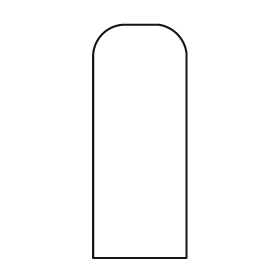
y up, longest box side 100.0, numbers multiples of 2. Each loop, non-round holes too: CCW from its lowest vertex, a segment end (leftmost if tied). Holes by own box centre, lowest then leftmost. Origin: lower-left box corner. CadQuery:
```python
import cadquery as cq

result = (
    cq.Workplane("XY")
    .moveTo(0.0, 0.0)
    .lineTo(40.0, 0.0)
    .lineTo(40.0, 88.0)
    .threePointArc((36.0, 96.0), (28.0, 100.0))
    .lineTo(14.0, 100.0)
    .threePointArc((4.0, 96.0), (0.0, 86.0))
    .close()
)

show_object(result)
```